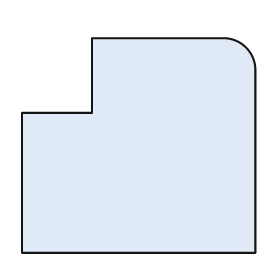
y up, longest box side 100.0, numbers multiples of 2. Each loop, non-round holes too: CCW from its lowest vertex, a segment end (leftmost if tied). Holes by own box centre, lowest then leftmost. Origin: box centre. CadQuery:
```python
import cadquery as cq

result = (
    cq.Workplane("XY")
    .moveTo(-50.0, -46.0)
    .lineTo(50.0, -46.0)
    .lineTo(50.0, 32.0)
    .threePointArc((46.0, 42.0), (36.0, 46.0))
    .lineTo(-20.0, 46.0)
    .lineTo(-20.0, 14.0)
    .lineTo(-50.0, 14.0)
    .close()
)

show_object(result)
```